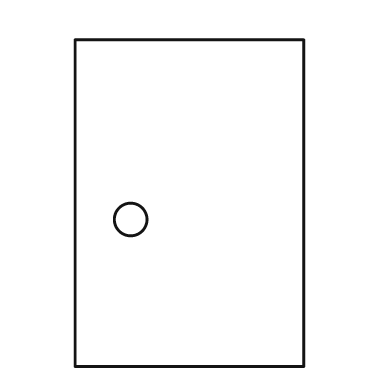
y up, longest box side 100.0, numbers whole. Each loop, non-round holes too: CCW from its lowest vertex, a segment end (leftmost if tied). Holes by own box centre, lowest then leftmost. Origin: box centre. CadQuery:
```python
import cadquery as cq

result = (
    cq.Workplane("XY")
    .moveTo(-35.0, -50.0)
    .lineTo(35.0, -50.0)
    .lineTo(35.0, 50.0)
    .lineTo(-35.0, 50.0)
    .close()
    .moveTo(-18.0, -5.0)
    .circle(5.0)
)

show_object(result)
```